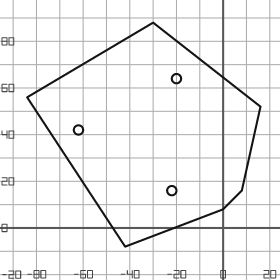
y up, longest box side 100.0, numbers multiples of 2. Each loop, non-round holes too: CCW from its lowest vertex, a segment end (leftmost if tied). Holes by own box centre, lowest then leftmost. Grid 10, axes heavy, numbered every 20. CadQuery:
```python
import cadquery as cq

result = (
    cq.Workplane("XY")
    .moveTo(-42.0, -8.0)
    .lineTo(0.0, 8.0)
    .lineTo(8.0, 16.0)
    .lineTo(16.0, 52.0)
    .lineTo(-30.0, 88.0)
    .lineTo(-84.0, 56.0)
    .close()
    .moveTo(-22.0, 16.0)
    .circle(2.0)
    .moveTo(-62.0, 42.0)
    .circle(2.0)
    .moveTo(-20.0, 64.0)
    .circle(2.0)
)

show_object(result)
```